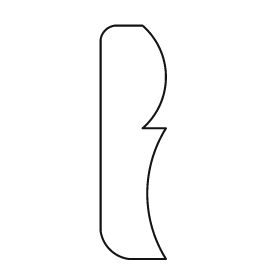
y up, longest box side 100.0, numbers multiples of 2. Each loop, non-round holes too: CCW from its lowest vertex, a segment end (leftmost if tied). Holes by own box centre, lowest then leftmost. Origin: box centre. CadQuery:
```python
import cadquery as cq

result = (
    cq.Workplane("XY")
    .moveTo(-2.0, -50.0)
    .lineTo(14.0, -50.0)
    .threePointArc((6.0, -22.0), (14.0, 6.0))
    .lineTo(4.0, 6.0)
    .threePointArc((14.0, 28.0), (4.0, 50.0))
    .lineTo(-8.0, 50.0)
    .threePointArc((-12.0, 48.0), (-14.0, 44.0))
    .lineTo(-14.0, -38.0)
    .threePointArc((-10.0, -46.0), (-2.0, -50.0))
    .close()
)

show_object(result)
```